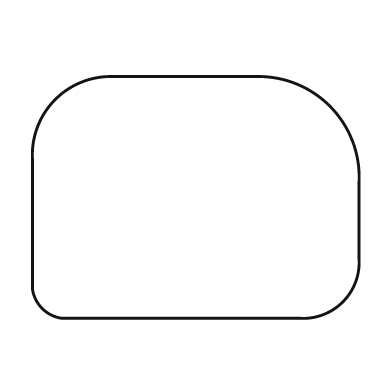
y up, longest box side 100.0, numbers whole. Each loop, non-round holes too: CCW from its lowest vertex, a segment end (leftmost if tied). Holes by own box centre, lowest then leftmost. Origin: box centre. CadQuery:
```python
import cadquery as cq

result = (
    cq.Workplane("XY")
    .moveTo(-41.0, -37.0)
    .lineTo(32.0, -37.0)
    .threePointArc((45.0, -32.0), (50.0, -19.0))
    .lineTo(50.0, 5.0)
    .threePointArc((41.0, 28.0), (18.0, 37.0))
    .lineTo(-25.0, 37.0)
    .threePointArc((-43.0, 30.0), (-50.0, 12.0))
    .lineTo(-50.0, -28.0)
    .threePointArc((-47.0, -34.0), (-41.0, -37.0))
    .close()
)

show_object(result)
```